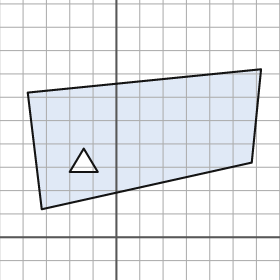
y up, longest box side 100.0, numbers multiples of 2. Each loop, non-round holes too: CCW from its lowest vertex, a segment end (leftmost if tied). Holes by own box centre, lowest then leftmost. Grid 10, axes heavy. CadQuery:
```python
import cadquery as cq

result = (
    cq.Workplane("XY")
    .moveTo(-32.0, 12.0)
    .lineTo(58.0, 32.0)
    .lineTo(62.0, 72.0)
    .lineTo(-38.0, 62.0)
    .close()
    .moveTo(-20.0, 28.0)
    .lineTo(-8.0, 28.0)
    .lineTo(-14.0, 38.0)
    .close()
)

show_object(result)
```